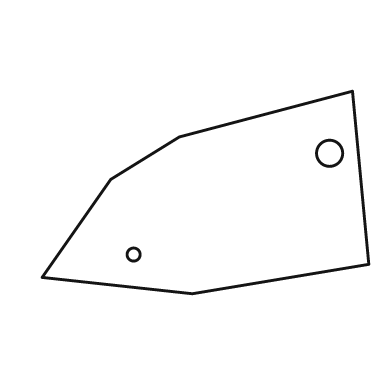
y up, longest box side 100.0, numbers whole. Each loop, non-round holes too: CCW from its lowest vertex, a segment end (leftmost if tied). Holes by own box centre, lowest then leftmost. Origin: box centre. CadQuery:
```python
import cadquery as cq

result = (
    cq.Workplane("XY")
    .moveTo(-4.0, -31.0)
    .lineTo(50.0, -22.0)
    .lineTo(45.0, 31.0)
    .lineTo(-8.0, 17.0)
    .lineTo(-29.0, 4.0)
    .lineTo(-50.0, -26.0)
    .close()
    .moveTo(-22.0, -19.0)
    .circle(2.0)
    .moveTo(38.0, 12.0)
    .circle(4.0)
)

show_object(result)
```